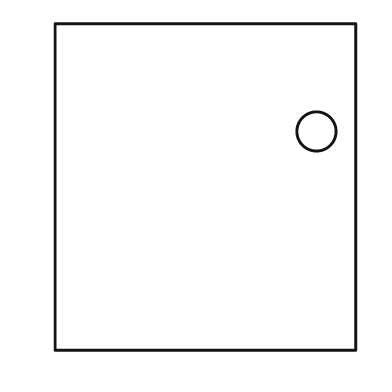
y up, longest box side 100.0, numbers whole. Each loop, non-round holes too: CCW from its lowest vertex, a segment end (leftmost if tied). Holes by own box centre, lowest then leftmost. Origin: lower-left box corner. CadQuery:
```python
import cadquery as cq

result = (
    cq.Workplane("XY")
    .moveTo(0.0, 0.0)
    .lineTo(92.0, 0.0)
    .lineTo(92.0, 100.0)
    .lineTo(0.0, 100.0)
    .close()
    .moveTo(80.0, 67.0)
    .circle(6.0)
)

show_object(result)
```